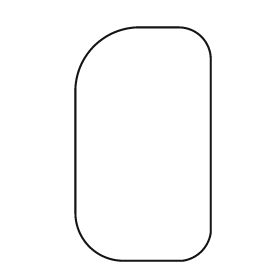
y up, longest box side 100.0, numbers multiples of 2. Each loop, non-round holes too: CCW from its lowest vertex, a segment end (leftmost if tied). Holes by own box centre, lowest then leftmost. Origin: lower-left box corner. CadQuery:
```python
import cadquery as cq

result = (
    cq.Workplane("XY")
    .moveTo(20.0, 0.0)
    .lineTo(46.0, 0.0)
    .threePointArc((54.0, 4.0), (58.0, 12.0))
    .lineTo(58.0, 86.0)
    .threePointArc((54.0, 96.0), (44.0, 100.0))
    .lineTo(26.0, 100.0)
    .threePointArc((8.0, 92.0), (0.0, 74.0))
    .lineTo(0.0, 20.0)
    .threePointArc((6.0, 6.0), (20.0, 0.0))
    .close()
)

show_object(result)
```